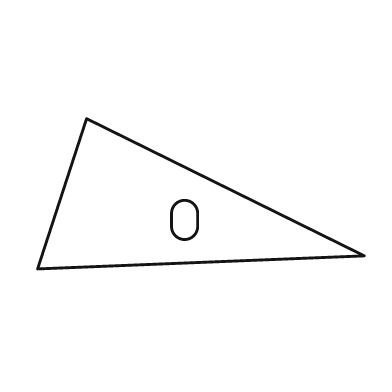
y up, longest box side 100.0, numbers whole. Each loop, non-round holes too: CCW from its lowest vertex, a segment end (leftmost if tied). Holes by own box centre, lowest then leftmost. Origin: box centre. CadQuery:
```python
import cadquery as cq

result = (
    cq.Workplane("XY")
    .moveTo(-50.0, -23.0)
    .lineTo(50.0, -19.0)
    .lineTo(-35.0, 23.0)
    .close()
    .moveTo(-9.0, -10.0)
    .threePointArc((-5.0, -14.0), (-1.0, -10.0))
    .lineTo(-1.0, -6.0)
    .threePointArc((-5.0, -2.0), (-9.0, -6.0))
    .close()
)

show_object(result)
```